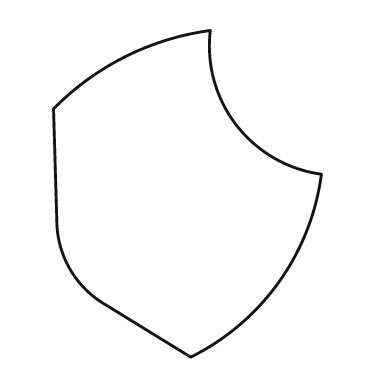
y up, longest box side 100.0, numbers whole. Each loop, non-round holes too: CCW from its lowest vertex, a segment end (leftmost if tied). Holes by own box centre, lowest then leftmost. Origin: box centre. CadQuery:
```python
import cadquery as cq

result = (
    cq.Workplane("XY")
    .moveTo(1.0, -50.0)
    .threePointArc((28.0, -27.0), (41.0, 6.0))
    .threePointArc((15.0, 21.0), (7.0, 50.0))
    .threePointArc((-19.0, 42.0), (-41.0, 26.0))
    .lineTo(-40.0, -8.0)
    .threePointArc((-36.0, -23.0), (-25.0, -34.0))
    .close()
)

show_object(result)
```